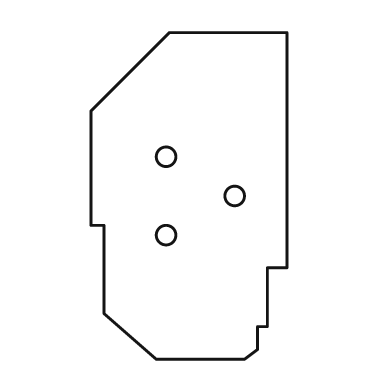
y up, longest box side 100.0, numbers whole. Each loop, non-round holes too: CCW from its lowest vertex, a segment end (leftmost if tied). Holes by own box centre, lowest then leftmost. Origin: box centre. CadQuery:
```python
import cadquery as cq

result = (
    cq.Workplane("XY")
    .moveTo(-10.0, -50.0)
    .lineTo(17.0, -50.0)
    .lineTo(21.0, -47.0)
    .lineTo(21.0, -40.0)
    .lineTo(24.0, -40.0)
    .lineTo(24.0, -22.0)
    .lineTo(30.0, -22.0)
    .lineTo(30.0, 50.0)
    .lineTo(-6.0, 50.0)
    .lineTo(-30.0, 26.0)
    .lineTo(-30.0, -9.0)
    .lineTo(-26.0, -9.0)
    .lineTo(-26.0, -36.0)
    .close()
    .moveTo(-7.0, -12.0)
    .circle(3.0)
    .moveTo(14.0, 0.0)
    .circle(3.0)
    .moveTo(-7.0, 12.0)
    .circle(3.0)
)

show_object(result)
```